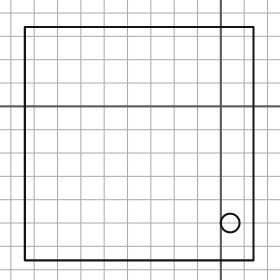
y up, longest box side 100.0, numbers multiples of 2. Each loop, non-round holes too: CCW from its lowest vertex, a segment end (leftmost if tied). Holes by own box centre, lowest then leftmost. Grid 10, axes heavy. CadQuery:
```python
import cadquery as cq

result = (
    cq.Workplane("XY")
    .moveTo(-84.0, -66.0)
    .lineTo(14.0, -66.0)
    .lineTo(14.0, 34.0)
    .lineTo(-84.0, 34.0)
    .close()
    .moveTo(4.0, -50.0)
    .circle(4.0)
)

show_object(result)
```